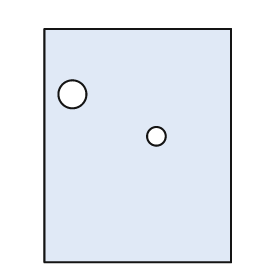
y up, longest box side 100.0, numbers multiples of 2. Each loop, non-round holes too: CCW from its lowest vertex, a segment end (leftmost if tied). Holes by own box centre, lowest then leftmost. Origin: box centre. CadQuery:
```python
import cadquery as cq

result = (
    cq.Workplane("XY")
    .moveTo(-40.0, -50.0)
    .lineTo(40.0, -50.0)
    .lineTo(40.0, 50.0)
    .lineTo(-40.0, 50.0)
    .close()
    .moveTo(8.0, 4.0)
    .circle(4.0)
    .moveTo(-28.0, 22.0)
    .circle(6.0)
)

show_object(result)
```